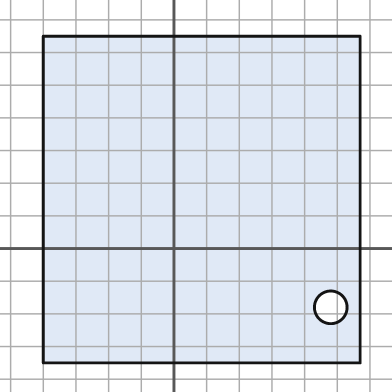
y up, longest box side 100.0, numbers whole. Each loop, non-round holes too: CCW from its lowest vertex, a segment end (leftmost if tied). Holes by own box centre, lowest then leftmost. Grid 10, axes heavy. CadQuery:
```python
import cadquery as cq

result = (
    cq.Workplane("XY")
    .moveTo(-40.0, -35.0)
    .lineTo(57.0, -35.0)
    .lineTo(57.0, 65.0)
    .lineTo(-40.0, 65.0)
    .close()
    .moveTo(48.0, -18.0)
    .circle(5.0)
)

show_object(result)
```